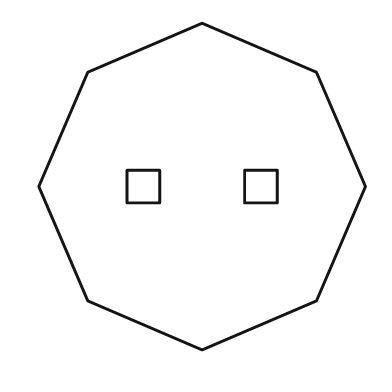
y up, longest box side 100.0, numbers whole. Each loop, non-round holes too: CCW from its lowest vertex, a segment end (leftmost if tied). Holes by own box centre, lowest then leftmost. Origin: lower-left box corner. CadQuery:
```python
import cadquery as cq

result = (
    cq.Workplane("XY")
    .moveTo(50.0, 0.0)
    .lineTo(85.0, 15.0)
    .lineTo(100.0, 50.0)
    .lineTo(85.0, 85.0)
    .lineTo(50.0, 100.0)
    .lineTo(15.0, 85.0)
    .lineTo(0.0, 50.0)
    .lineTo(15.0, 15.0)
    .close()
    .moveTo(27.0, 45.0)
    .lineTo(37.0, 45.0)
    .lineTo(37.0, 55.0)
    .lineTo(27.0, 55.0)
    .close()
    .moveTo(63.0, 45.0)
    .lineTo(73.0, 45.0)
    .lineTo(73.0, 55.0)
    .lineTo(63.0, 55.0)
    .close()
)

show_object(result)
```